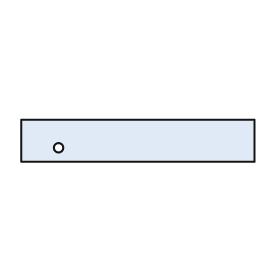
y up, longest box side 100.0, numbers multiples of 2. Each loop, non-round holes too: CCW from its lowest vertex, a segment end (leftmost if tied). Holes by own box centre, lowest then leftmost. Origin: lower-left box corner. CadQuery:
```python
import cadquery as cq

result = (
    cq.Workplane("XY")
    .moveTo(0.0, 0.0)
    .lineTo(100.0, 0.0)
    .lineTo(100.0, 18.0)
    .lineTo(0.0, 18.0)
    .close()
    .moveTo(16.0, 6.0)
    .circle(2.0)
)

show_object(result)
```